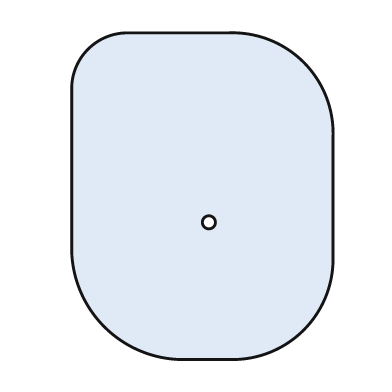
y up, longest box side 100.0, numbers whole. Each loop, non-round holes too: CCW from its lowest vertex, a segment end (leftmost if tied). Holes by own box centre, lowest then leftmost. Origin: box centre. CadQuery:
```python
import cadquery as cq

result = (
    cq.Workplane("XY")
    .moveTo(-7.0, -50.0)
    .lineTo(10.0, -50.0)
    .threePointArc((31.0, -41.0), (40.0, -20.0))
    .lineTo(40.0, 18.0)
    .threePointArc((31.0, 41.0), (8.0, 50.0))
    .lineTo(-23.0, 50.0)
    .threePointArc((-35.0, 45.0), (-40.0, 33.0))
    .lineTo(-40.0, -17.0)
    .threePointArc((-30.0, -40.0), (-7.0, -50.0))
    .close()
    .moveTo(2.0, -8.0)
    .circle(2.0)
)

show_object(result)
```